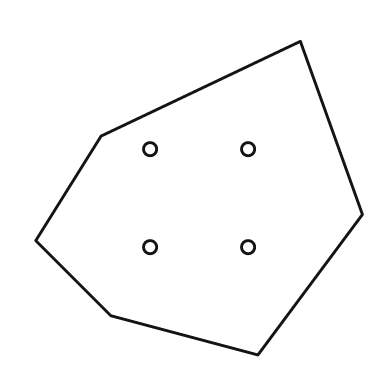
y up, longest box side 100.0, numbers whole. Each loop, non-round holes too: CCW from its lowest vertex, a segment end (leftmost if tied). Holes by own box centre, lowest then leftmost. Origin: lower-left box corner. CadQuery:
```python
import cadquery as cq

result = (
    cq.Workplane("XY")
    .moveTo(68.0, 0.0)
    .lineTo(100.0, 43.0)
    .lineTo(81.0, 96.0)
    .lineTo(20.0, 67.0)
    .lineTo(0.0, 35.0)
    .lineTo(23.0, 12.0)
    .close()
    .moveTo(35.0, 33.0)
    .circle(2.0)
    .moveTo(65.0, 33.0)
    .circle(2.0)
    .moveTo(35.0, 63.0)
    .circle(2.0)
    .moveTo(65.0, 63.0)
    .circle(2.0)
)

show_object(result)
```